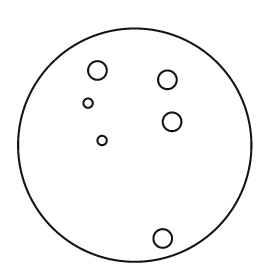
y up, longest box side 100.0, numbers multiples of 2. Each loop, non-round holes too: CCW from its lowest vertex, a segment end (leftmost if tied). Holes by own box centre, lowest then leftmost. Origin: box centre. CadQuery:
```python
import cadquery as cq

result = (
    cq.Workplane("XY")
    .moveTo(0.0, 0.0)
    .circle(50.0)
    .moveTo(12.0, -40.0)
    .circle(4.0)
    .moveTo(-14.0, 2.0)
    .circle(2.0)
    .moveTo(16.0, 10.0)
    .circle(4.0)
    .moveTo(-20.0, 18.0)
    .circle(2.0)
    .moveTo(14.0, 28.0)
    .circle(4.0)
    .moveTo(-16.0, 32.0)
    .circle(4.0)
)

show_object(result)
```